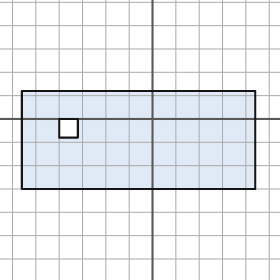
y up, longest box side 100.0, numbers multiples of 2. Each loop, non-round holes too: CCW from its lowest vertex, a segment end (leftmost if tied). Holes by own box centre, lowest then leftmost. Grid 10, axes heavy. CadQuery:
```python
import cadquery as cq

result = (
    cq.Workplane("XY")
    .moveTo(-56.0, -30.0)
    .lineTo(44.0, -30.0)
    .lineTo(44.0, 12.0)
    .lineTo(-56.0, 12.0)
    .close()
    .moveTo(-40.0, -8.0)
    .lineTo(-32.0, -8.0)
    .lineTo(-32.0, 0.0)
    .lineTo(-40.0, 0.0)
    .close()
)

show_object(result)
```